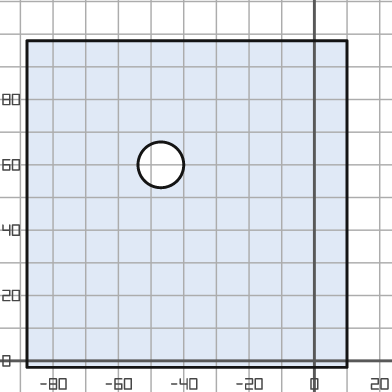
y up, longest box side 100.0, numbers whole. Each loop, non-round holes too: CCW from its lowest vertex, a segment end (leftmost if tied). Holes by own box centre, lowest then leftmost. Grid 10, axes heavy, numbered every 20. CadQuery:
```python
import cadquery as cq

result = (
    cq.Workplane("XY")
    .moveTo(-88.0, -2.0)
    .lineTo(10.0, -2.0)
    .lineTo(10.0, 98.0)
    .lineTo(-88.0, 98.0)
    .close()
    .moveTo(-47.0, 60.0)
    .circle(7.0)
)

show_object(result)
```